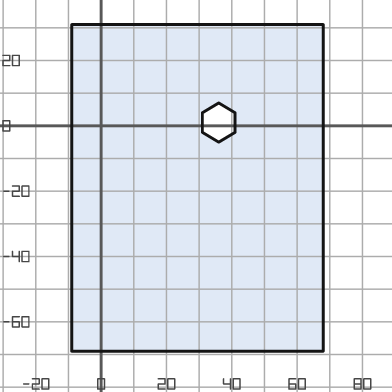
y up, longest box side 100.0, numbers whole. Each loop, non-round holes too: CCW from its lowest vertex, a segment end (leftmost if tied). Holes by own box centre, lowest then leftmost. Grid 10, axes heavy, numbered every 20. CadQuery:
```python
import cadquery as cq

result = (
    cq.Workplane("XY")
    .moveTo(-9.0, -69.0)
    .lineTo(68.0, -69.0)
    .lineTo(68.0, 31.0)
    .lineTo(-9.0, 31.0)
    .close()
    .moveTo(36.0, -5.0)
    .lineTo(41.0, -2.0)
    .lineTo(41.0, 4.0)
    .lineTo(36.0, 7.0)
    .lineTo(31.0, 4.0)
    .lineTo(31.0, -2.0)
    .close()
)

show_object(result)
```